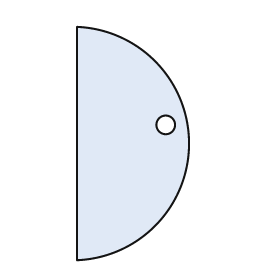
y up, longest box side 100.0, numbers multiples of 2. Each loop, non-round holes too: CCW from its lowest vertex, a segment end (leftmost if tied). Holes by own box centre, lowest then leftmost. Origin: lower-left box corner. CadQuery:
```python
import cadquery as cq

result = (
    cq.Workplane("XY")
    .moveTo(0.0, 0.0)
    .threePointArc((48.0, 50.0), (0.0, 100.0))
    .close()
    .moveTo(38.0, 58.0)
    .circle(4.0)
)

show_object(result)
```